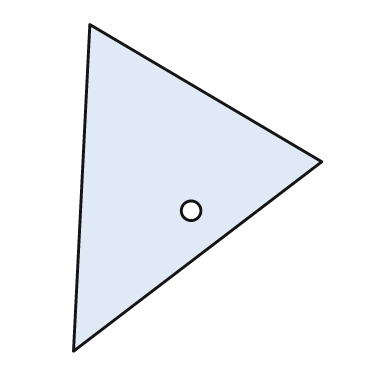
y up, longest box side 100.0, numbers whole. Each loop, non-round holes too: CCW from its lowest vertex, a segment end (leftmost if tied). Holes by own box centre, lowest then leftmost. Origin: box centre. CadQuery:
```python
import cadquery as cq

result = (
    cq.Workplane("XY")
    .moveTo(-38.0, -50.0)
    .lineTo(38.0, 8.0)
    .lineTo(-33.0, 50.0)
    .close()
    .moveTo(-2.0, -7.0)
    .circle(3.0)
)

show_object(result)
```